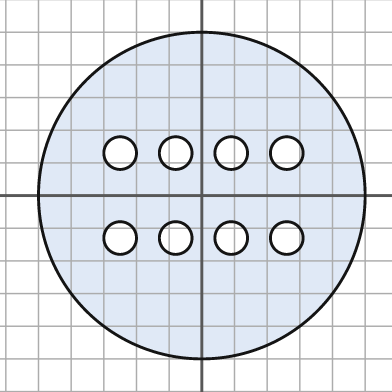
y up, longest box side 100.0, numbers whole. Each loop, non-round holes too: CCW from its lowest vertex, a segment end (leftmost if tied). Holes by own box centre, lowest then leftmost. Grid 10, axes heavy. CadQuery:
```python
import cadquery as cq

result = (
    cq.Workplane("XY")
    .moveTo(0.0, 0.0)
    .circle(50.0)
    .moveTo(-25.0, -13.0)
    .circle(5.0)
    .moveTo(-8.0, -13.0)
    .circle(5.0)
    .moveTo(9.0, -13.0)
    .circle(5.0)
    .moveTo(26.0, -13.0)
    .circle(5.0)
    .moveTo(-25.0, 13.0)
    .circle(5.0)
    .moveTo(-8.0, 13.0)
    .circle(5.0)
    .moveTo(9.0, 13.0)
    .circle(5.0)
    .moveTo(26.0, 13.0)
    .circle(5.0)
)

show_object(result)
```